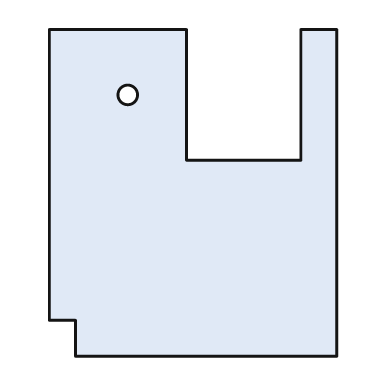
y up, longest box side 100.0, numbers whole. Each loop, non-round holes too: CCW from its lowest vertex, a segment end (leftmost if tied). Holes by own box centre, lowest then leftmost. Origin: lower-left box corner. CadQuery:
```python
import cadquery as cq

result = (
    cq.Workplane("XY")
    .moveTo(8.0, 0.0)
    .lineTo(88.0, 0.0)
    .lineTo(88.0, 100.0)
    .lineTo(77.0, 100.0)
    .lineTo(77.0, 60.0)
    .lineTo(42.0, 60.0)
    .lineTo(42.0, 100.0)
    .lineTo(0.0, 100.0)
    .lineTo(0.0, 11.0)
    .lineTo(8.0, 11.0)
    .close()
    .moveTo(24.0, 80.0)
    .circle(3.0)
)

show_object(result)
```